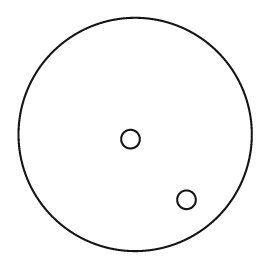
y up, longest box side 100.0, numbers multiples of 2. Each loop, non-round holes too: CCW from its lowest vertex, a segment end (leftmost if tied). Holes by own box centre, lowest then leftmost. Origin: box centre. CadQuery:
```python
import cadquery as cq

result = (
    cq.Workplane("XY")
    .moveTo(0.0, 0.0)
    .circle(50.0)
    .moveTo(22.0, -28.0)
    .circle(4.0)
    .moveTo(-2.0, -2.0)
    .circle(4.0)
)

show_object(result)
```